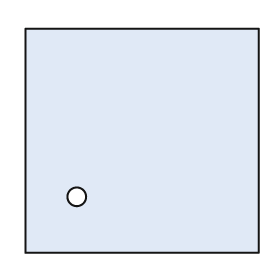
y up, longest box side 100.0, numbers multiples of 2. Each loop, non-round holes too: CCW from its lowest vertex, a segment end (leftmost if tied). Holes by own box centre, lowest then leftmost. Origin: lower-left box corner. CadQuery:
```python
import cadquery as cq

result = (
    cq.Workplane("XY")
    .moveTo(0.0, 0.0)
    .lineTo(100.0, 0.0)
    .lineTo(100.0, 96.0)
    .lineTo(0.0, 96.0)
    .close()
    .moveTo(22.0, 24.0)
    .circle(4.0)
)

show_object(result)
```